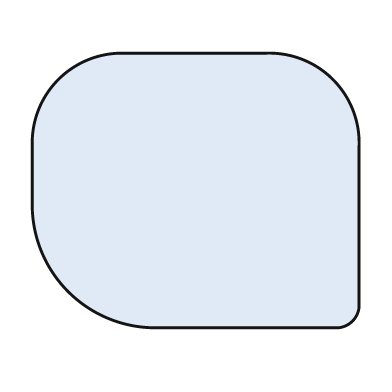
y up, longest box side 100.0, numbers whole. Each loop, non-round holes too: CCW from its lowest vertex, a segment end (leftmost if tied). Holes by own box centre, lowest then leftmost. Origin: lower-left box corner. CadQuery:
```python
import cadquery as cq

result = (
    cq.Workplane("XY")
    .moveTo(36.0, 0.0)
    .lineTo(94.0, 0.0)
    .threePointArc((98.0, 2.0), (100.0, 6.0))
    .lineTo(100.0, 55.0)
    .threePointArc((92.0, 76.0), (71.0, 84.0))
    .lineTo(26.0, 84.0)
    .threePointArc((8.0, 76.0), (0.0, 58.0))
    .lineTo(0.0, 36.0)
    .threePointArc((11.0, 11.0), (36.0, 0.0))
    .close()
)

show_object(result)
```